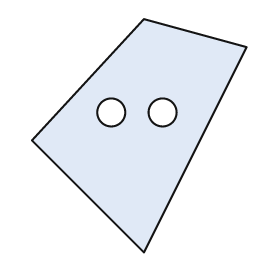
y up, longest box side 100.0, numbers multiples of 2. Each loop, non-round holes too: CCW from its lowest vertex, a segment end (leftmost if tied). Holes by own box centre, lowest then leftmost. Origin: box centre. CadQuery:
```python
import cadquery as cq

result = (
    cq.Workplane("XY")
    .moveTo(2.0, -50.0)
    .lineTo(46.0, 38.0)
    .lineTo(2.0, 50.0)
    .lineTo(-46.0, -2.0)
    .close()
    .moveTo(-12.0, 10.0)
    .circle(6.0)
    .moveTo(10.0, 10.0)
    .circle(6.0)
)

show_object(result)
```